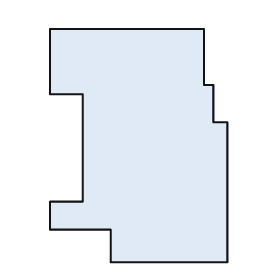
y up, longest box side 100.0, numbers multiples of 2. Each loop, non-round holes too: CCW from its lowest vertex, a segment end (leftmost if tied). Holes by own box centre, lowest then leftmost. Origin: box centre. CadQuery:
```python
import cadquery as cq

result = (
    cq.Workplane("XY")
    .moveTo(-12.0, -50.0)
    .lineTo(38.0, -50.0)
    .lineTo(38.0, 10.0)
    .lineTo(32.0, 10.0)
    .lineTo(32.0, 26.0)
    .lineTo(28.0, 26.0)
    .lineTo(28.0, 50.0)
    .lineTo(-38.0, 50.0)
    .lineTo(-38.0, 22.0)
    .lineTo(-24.0, 22.0)
    .lineTo(-24.0, -24.0)
    .lineTo(-38.0, -24.0)
    .lineTo(-38.0, -36.0)
    .lineTo(-12.0, -36.0)
    .close()
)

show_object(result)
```